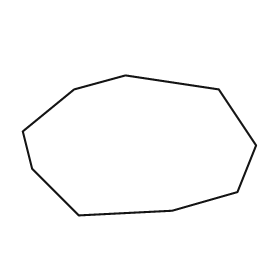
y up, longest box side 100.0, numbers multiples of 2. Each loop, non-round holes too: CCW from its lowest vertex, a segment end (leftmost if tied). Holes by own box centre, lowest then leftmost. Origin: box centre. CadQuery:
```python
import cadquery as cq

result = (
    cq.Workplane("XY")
    .moveTo(-26.0, -30.0)
    .lineTo(14.0, -28.0)
    .lineTo(42.0, -20.0)
    .lineTo(50.0, 0.0)
    .lineTo(34.0, 24.0)
    .lineTo(-6.0, 30.0)
    .lineTo(-28.0, 24.0)
    .lineTo(-50.0, 6.0)
    .lineTo(-46.0, -10.0)
    .close()
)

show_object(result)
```